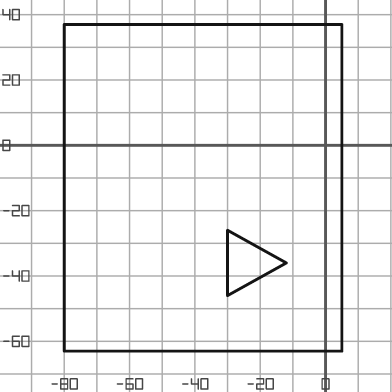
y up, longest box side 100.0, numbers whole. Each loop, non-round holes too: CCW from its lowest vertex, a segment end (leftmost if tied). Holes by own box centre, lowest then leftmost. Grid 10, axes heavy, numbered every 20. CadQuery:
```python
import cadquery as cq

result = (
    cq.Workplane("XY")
    .moveTo(-80.0, -63.0)
    .lineTo(5.0, -63.0)
    .lineTo(5.0, 37.0)
    .lineTo(-80.0, 37.0)
    .close()
    .moveTo(-30.0, -46.0)
    .lineTo(-12.0, -36.0)
    .lineTo(-30.0, -26.0)
    .close()
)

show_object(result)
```